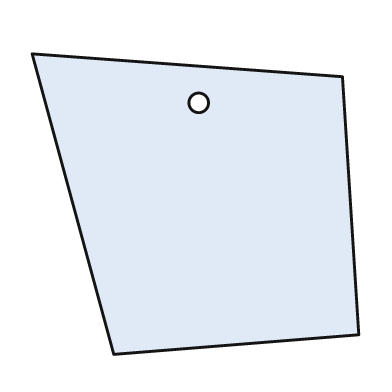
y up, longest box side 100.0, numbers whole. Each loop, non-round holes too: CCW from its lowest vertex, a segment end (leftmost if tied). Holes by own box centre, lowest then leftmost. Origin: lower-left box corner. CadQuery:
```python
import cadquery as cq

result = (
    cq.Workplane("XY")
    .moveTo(25.0, 0.0)
    .lineTo(100.0, 6.0)
    .lineTo(95.0, 85.0)
    .lineTo(0.0, 92.0)
    .close()
    .moveTo(51.0, 77.0)
    .circle(3.0)
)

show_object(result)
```